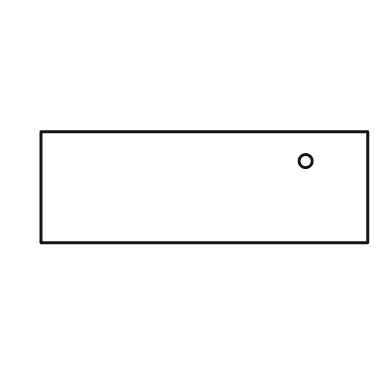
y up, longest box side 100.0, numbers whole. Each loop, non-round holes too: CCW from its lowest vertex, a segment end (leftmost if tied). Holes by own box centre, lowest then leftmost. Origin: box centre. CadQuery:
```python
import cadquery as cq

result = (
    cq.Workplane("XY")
    .moveTo(-50.0, -17.0)
    .lineTo(50.0, -17.0)
    .lineTo(50.0, 17.0)
    .lineTo(-50.0, 17.0)
    .close()
    .moveTo(31.0, 8.0)
    .circle(2.0)
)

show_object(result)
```